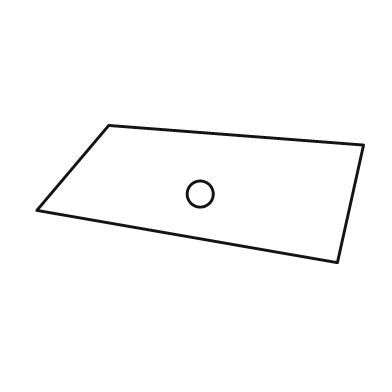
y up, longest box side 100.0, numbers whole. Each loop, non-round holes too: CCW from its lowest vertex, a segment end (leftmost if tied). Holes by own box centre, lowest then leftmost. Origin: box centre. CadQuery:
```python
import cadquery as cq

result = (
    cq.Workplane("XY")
    .moveTo(42.0, -21.0)
    .lineTo(50.0, 15.0)
    .lineTo(-28.0, 21.0)
    .lineTo(-50.0, -5.0)
    .close()
    .moveTo(0.0, 0.0)
    .circle(4.0)
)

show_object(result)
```